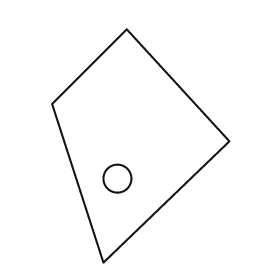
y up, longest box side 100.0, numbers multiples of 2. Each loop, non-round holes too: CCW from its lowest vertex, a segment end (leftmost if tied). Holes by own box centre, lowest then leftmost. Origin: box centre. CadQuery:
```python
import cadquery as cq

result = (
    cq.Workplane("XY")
    .moveTo(-16.0, -50.0)
    .lineTo(38.0, 2.0)
    .lineTo(-6.0, 50.0)
    .lineTo(-38.0, 18.0)
    .close()
    .moveTo(-10.0, -14.0)
    .circle(6.0)
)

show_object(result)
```